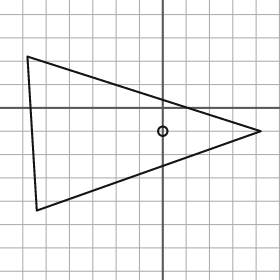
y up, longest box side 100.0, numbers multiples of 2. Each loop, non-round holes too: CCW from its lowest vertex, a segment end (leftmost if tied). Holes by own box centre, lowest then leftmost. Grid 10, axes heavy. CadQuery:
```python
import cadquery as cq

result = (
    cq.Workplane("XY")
    .moveTo(-54.0, -44.0)
    .lineTo(42.0, -10.0)
    .lineTo(-58.0, 22.0)
    .close()
    .moveTo(0.0, -10.0)
    .circle(2.0)
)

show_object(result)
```